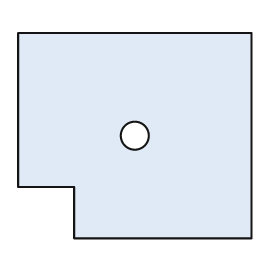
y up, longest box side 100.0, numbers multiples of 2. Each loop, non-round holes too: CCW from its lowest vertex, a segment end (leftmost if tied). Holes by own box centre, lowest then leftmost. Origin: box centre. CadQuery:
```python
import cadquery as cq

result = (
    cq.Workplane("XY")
    .moveTo(-26.0, -44.0)
    .lineTo(50.0, -44.0)
    .lineTo(50.0, 44.0)
    .lineTo(-50.0, 44.0)
    .lineTo(-50.0, -22.0)
    .lineTo(-26.0, -22.0)
    .close()
    .moveTo(0.0, 0.0)
    .circle(6.0)
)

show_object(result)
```